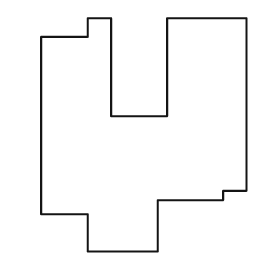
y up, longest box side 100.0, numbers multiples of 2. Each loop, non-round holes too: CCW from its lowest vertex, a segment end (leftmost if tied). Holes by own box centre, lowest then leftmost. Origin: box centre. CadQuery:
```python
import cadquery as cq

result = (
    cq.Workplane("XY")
    .moveTo(-24.0, -50.0)
    .lineTo(6.0, -50.0)
    .lineTo(6.0, -28.0)
    .lineTo(34.0, -28.0)
    .lineTo(34.0, -24.0)
    .lineTo(44.0, -24.0)
    .lineTo(44.0, 50.0)
    .lineTo(10.0, 50.0)
    .lineTo(10.0, 8.0)
    .lineTo(-14.0, 8.0)
    .lineTo(-14.0, 50.0)
    .lineTo(-24.0, 50.0)
    .lineTo(-24.0, 42.0)
    .lineTo(-44.0, 42.0)
    .lineTo(-44.0, -34.0)
    .lineTo(-24.0, -34.0)
    .close()
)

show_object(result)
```